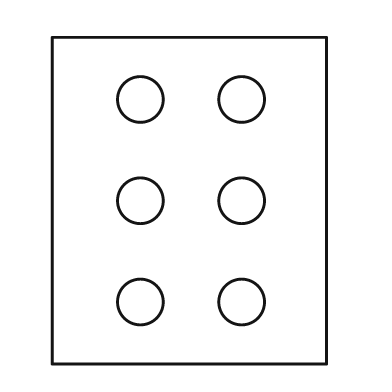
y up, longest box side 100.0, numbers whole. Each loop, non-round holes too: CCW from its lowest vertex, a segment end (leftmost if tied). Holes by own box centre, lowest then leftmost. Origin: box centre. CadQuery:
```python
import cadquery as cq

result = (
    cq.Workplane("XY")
    .moveTo(-42.0, -50.0)
    .lineTo(42.0, -50.0)
    .lineTo(42.0, 50.0)
    .lineTo(-42.0, 50.0)
    .close()
    .moveTo(-15.0, -31.0)
    .circle(7.0)
    .moveTo(16.0, -31.0)
    .circle(7.0)
    .moveTo(-15.0, 0.0)
    .circle(7.0)
    .moveTo(16.0, 0.0)
    .circle(7.0)
    .moveTo(-15.0, 31.0)
    .circle(7.0)
    .moveTo(16.0, 31.0)
    .circle(7.0)
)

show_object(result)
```